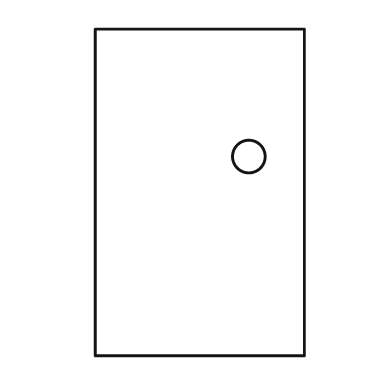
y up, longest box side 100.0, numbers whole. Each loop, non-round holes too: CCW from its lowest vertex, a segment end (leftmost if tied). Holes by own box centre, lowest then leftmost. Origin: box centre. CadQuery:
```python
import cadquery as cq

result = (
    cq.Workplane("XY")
    .moveTo(-32.0, -50.0)
    .lineTo(32.0, -50.0)
    .lineTo(32.0, 50.0)
    .lineTo(-32.0, 50.0)
    .close()
    .moveTo(15.0, 11.0)
    .circle(5.0)
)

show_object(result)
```